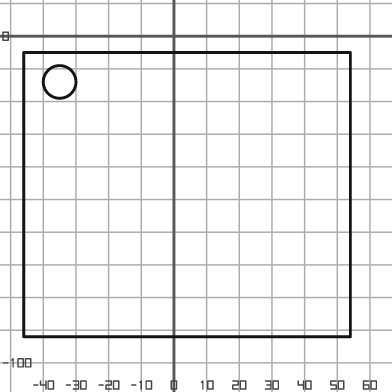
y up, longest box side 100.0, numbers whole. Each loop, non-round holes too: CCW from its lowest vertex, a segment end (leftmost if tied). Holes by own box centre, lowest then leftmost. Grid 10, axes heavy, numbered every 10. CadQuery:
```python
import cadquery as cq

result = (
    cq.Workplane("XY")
    .moveTo(-46.0, -92.0)
    .lineTo(54.0, -92.0)
    .lineTo(54.0, -5.0)
    .lineTo(-46.0, -5.0)
    .close()
    .moveTo(-35.0, -14.0)
    .circle(5.0)
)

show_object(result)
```